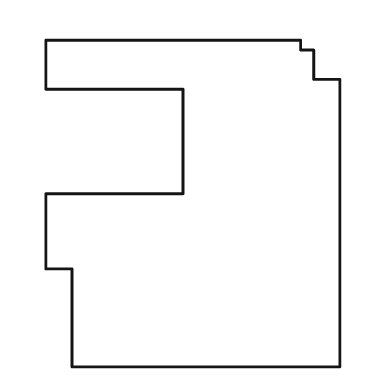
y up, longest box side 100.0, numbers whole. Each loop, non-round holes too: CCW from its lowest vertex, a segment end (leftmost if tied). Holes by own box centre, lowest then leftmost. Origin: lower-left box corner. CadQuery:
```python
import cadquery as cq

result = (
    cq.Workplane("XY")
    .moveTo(8.0, 0.0)
    .lineTo(90.0, 0.0)
    .lineTo(90.0, 88.0)
    .lineTo(82.0, 88.0)
    .lineTo(82.0, 97.0)
    .lineTo(78.0, 97.0)
    .lineTo(78.0, 100.0)
    .lineTo(0.0, 100.0)
    .lineTo(0.0, 85.0)
    .lineTo(42.0, 85.0)
    .lineTo(42.0, 53.0)
    .lineTo(0.0, 53.0)
    .lineTo(0.0, 30.0)
    .lineTo(8.0, 30.0)
    .close()
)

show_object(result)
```